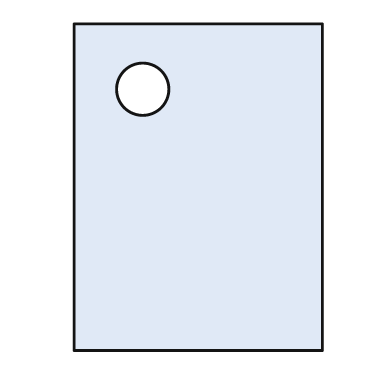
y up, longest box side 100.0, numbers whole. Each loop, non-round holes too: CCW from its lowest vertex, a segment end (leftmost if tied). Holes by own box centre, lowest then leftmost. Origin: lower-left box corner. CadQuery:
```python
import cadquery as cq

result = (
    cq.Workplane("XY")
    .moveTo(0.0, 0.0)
    .lineTo(76.0, 0.0)
    .lineTo(76.0, 100.0)
    .lineTo(0.0, 100.0)
    .close()
    .moveTo(21.0, 80.0)
    .circle(8.0)
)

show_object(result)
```